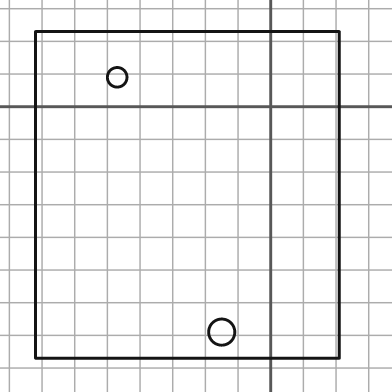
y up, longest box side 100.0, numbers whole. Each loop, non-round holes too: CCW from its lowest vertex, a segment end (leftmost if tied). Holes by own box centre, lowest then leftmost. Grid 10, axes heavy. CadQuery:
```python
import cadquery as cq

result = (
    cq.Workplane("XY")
    .moveTo(-72.0, -77.0)
    .lineTo(21.0, -77.0)
    .lineTo(21.0, 23.0)
    .lineTo(-72.0, 23.0)
    .close()
    .moveTo(-15.0, -69.0)
    .circle(4.0)
    .moveTo(-47.0, 9.0)
    .circle(3.0)
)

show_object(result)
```